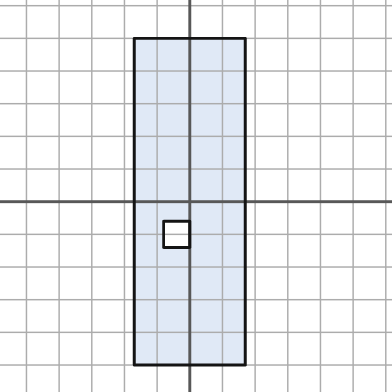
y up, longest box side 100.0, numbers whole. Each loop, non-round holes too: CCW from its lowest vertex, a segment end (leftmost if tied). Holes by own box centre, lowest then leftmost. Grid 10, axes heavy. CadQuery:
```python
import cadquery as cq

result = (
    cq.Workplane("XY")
    .moveTo(-17.0, -50.0)
    .lineTo(17.0, -50.0)
    .lineTo(17.0, 50.0)
    .lineTo(-17.0, 50.0)
    .close()
    .moveTo(-8.0, -14.0)
    .lineTo(0.0, -14.0)
    .lineTo(0.0, -6.0)
    .lineTo(-8.0, -6.0)
    .close()
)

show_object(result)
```